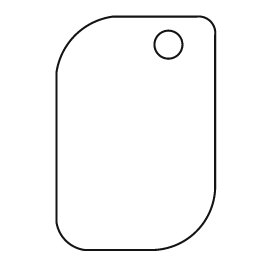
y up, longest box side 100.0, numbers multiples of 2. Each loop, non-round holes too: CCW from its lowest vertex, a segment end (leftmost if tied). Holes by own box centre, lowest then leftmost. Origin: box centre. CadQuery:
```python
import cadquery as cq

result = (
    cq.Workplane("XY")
    .moveTo(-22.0, -50.0)
    .lineTo(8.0, -50.0)
    .threePointArc((26.0, -42.0), (34.0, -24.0))
    .lineTo(34.0, 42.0)
    .threePointArc((32.0, 48.0), (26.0, 50.0))
    .lineTo(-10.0, 50.0)
    .threePointArc((-26.0, 42.0), (-34.0, 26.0))
    .lineTo(-34.0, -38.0)
    .threePointArc((-30.0, -46.0), (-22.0, -50.0))
    .close()
    .moveTo(14.0, 38.0)
    .circle(6.0)
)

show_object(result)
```